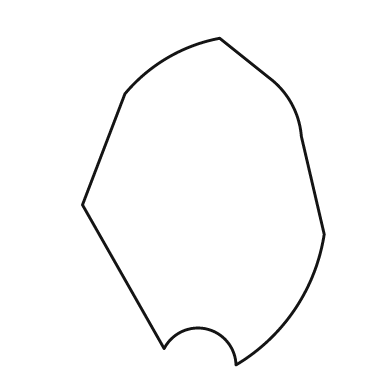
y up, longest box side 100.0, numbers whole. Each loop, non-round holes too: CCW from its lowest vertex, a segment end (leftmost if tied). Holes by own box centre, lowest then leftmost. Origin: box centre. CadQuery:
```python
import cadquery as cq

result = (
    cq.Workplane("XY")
    .moveTo(10.0, -50.0)
    .threePointArc((28.0, -33.0), (37.0, -10.0))
    .lineTo(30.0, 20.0)
    .threePointArc((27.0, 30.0), (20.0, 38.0))
    .lineTo(5.0, 50.0)
    .threePointArc((-11.0, 44.0), (-24.0, 33.0))
    .lineTo(-37.0, -1.0)
    .lineTo(-12.0, -45.0)
    .threePointArc((1.0, -39.0), (10.0, -50.0))
    .close()
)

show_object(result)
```